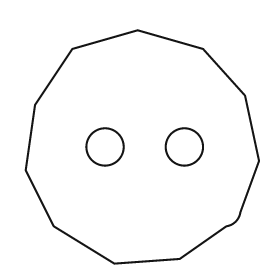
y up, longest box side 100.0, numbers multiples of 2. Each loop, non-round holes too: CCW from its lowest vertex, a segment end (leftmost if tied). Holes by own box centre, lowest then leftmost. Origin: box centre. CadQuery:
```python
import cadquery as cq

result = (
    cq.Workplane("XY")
    .moveTo(-12.0, -50.0)
    .lineTo(16.0, -48.0)
    .lineTo(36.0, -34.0)
    .threePointArc((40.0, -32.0), (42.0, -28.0))
    .lineTo(50.0, -6.0)
    .lineTo(44.0, 22.0)
    .lineTo(26.0, 42.0)
    .lineTo(-2.0, 50.0)
    .lineTo(-30.0, 42.0)
    .lineTo(-46.0, 18.0)
    .lineTo(-50.0, -10.0)
    .lineTo(-38.0, -34.0)
    .close()
    .moveTo(-16.0, 0.0)
    .circle(8.0)
    .moveTo(18.0, 0.0)
    .circle(8.0)
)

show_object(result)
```